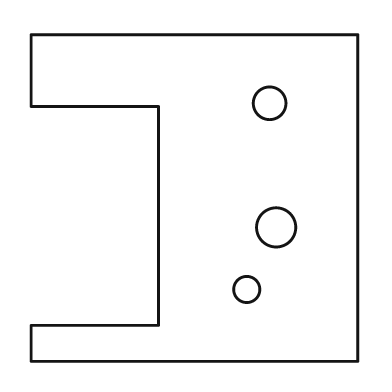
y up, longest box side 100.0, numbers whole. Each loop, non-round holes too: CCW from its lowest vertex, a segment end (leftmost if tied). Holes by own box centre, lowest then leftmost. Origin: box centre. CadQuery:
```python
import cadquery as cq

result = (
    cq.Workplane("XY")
    .moveTo(-50.0, -50.0)
    .lineTo(50.0, -50.0)
    .lineTo(50.0, 50.0)
    .lineTo(-50.0, 50.0)
    .lineTo(-50.0, 28.0)
    .lineTo(-11.0, 28.0)
    .lineTo(-11.0, -39.0)
    .lineTo(-50.0, -39.0)
    .close()
    .moveTo(16.0, -28.0)
    .circle(4.0)
    .moveTo(25.0, -9.0)
    .circle(6.0)
    .moveTo(23.0, 29.0)
    .circle(5.0)
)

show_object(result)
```